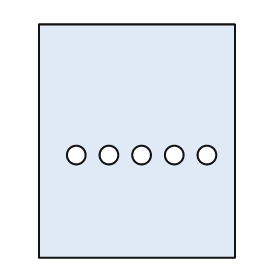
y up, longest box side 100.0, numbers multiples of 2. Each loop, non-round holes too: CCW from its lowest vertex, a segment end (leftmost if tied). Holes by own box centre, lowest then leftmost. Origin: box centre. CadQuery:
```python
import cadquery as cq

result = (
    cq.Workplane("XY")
    .moveTo(-42.0, -50.0)
    .lineTo(42.0, -50.0)
    .lineTo(42.0, 50.0)
    .lineTo(-42.0, 50.0)
    .close()
    .moveTo(-26.0, -6.0)
    .circle(4.0)
    .moveTo(-12.0, -6.0)
    .circle(4.0)
    .moveTo(2.0, -6.0)
    .circle(4.0)
    .moveTo(16.0, -6.0)
    .circle(4.0)
    .moveTo(30.0, -6.0)
    .circle(4.0)
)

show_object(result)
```